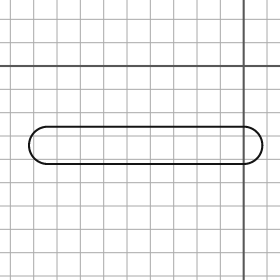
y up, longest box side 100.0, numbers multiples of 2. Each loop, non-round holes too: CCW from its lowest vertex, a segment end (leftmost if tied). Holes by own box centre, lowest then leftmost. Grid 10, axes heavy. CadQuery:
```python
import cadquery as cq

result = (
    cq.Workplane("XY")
    .moveTo(-84.0, -42.0)
    .lineTo(0.0, -42.0)
    .threePointArc((8.0, -34.0), (0.0, -26.0))
    .lineTo(-84.0, -26.0)
    .threePointArc((-92.0, -34.0), (-84.0, -42.0))
    .close()
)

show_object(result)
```